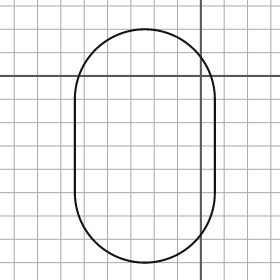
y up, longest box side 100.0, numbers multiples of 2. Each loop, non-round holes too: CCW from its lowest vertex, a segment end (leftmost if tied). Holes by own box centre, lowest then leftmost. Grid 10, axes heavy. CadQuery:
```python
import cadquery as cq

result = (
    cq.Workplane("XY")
    .moveTo(-54.0, -50.0)
    .threePointArc((-24.0, -80.0), (6.0, -50.0))
    .lineTo(6.0, -10.0)
    .threePointArc((-24.0, 20.0), (-54.0, -10.0))
    .close()
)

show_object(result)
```